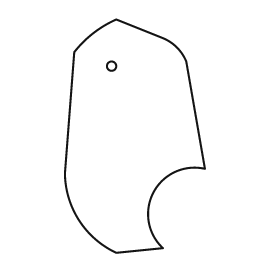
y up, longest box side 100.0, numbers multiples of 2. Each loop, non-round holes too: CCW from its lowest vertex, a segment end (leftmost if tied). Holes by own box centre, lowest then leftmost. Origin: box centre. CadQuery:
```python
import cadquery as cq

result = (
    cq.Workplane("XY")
    .moveTo(-8.0, -50.0)
    .lineTo(12.0, -48.0)
    .threePointArc((8.0, -24.0), (30.0, -14.0))
    .lineTo(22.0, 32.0)
    .threePointArc((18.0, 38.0), (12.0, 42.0))
    .lineTo(-8.0, 50.0)
    .threePointArc((-18.0, 44.0), (-26.0, 36.0))
    .lineTo(-30.0, -16.0)
    .threePointArc((-24.0, -36.0), (-8.0, -50.0))
    .close()
    .moveTo(-10.0, 30.0)
    .circle(2.0)
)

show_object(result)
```